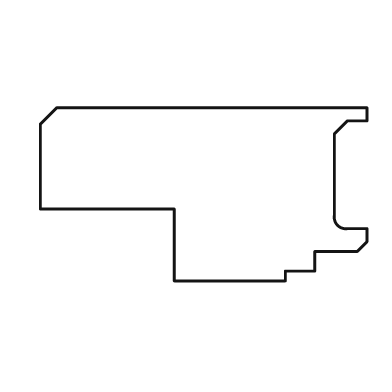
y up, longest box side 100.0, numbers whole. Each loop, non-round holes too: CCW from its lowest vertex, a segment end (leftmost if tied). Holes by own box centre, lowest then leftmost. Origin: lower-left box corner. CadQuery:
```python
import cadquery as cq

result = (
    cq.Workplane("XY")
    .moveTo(41.0, 0.0)
    .lineTo(75.0, 0.0)
    .lineTo(75.0, 3.0)
    .lineTo(84.0, 3.0)
    .lineTo(84.0, 9.0)
    .lineTo(97.0, 9.0)
    .lineTo(100.0, 12.0)
    .lineTo(100.0, 16.0)
    .lineTo(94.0, 16.0)
    .threePointArc((91.0, 17.0), (90.0, 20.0))
    .lineTo(90.0, 45.0)
    .lineTo(94.0, 49.0)
    .lineTo(100.0, 49.0)
    .lineTo(100.0, 53.0)
    .lineTo(5.0, 53.0)
    .lineTo(0.0, 48.0)
    .lineTo(0.0, 22.0)
    .lineTo(41.0, 22.0)
    .close()
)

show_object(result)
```